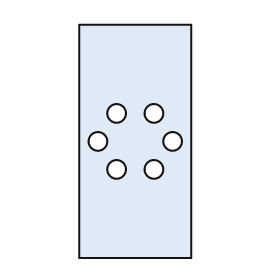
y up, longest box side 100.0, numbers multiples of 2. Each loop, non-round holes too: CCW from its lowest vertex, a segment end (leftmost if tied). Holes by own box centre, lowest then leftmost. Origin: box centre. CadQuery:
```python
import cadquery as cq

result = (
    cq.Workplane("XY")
    .moveTo(-24.0, -50.0)
    .lineTo(24.0, -50.0)
    .lineTo(24.0, 50.0)
    .lineTo(-24.0, 50.0)
    .close()
    .moveTo(-8.0, -12.0)
    .circle(4.0)
    .moveTo(8.0, -12.0)
    .circle(4.0)
    .moveTo(-16.0, 0.0)
    .circle(4.0)
    .moveTo(16.0, 0.0)
    .circle(4.0)
    .moveTo(-8.0, 12.0)
    .circle(4.0)
    .moveTo(8.0, 12.0)
    .circle(4.0)
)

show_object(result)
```